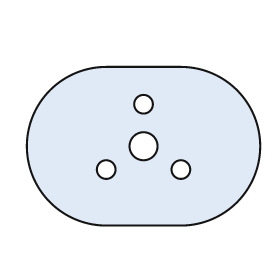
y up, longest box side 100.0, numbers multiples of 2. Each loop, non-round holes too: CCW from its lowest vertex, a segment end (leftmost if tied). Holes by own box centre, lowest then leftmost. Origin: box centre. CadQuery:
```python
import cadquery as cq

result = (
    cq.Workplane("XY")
    .moveTo(-16.0, -34.0)
    .lineTo(16.0, -34.0)
    .threePointArc((50.0, 0.0), (16.0, 34.0))
    .lineTo(-16.0, 34.0)
    .threePointArc((-50.0, 0.0), (-16.0, -34.0))
    .close()
    .moveTo(-16.0, -10.0)
    .circle(4.0)
    .moveTo(16.0, -10.0)
    .circle(4.0)
    .moveTo(0.0, 0.0)
    .circle(6.0)
    .moveTo(0.0, 18.0)
    .circle(4.0)
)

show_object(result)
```